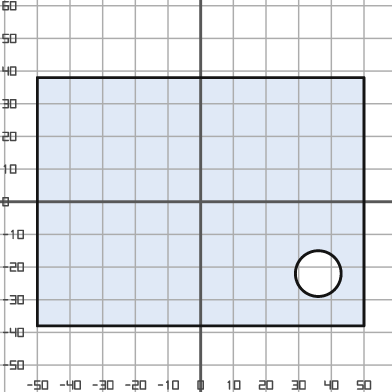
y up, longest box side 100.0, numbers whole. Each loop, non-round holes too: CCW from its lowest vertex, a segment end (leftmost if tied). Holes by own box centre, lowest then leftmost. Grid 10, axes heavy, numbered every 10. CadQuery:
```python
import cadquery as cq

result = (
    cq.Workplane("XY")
    .moveTo(-50.0, -38.0)
    .lineTo(50.0, -38.0)
    .lineTo(50.0, 38.0)
    .lineTo(-50.0, 38.0)
    .close()
    .moveTo(36.0, -22.0)
    .circle(7.0)
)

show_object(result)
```